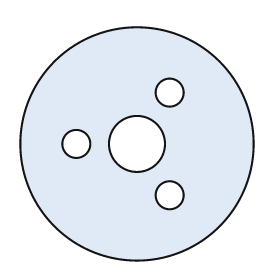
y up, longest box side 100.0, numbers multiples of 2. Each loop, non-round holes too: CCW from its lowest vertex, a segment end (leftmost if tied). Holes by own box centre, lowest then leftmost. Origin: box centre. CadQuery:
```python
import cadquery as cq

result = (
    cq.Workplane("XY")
    .moveTo(0.0, 0.0)
    .circle(50.0)
    .moveTo(14.0, -22.0)
    .circle(6.0)
    .moveTo(-26.0, 0.0)
    .circle(6.0)
    .moveTo(0.0, 0.0)
    .circle(12.0)
    .moveTo(14.0, 22.0)
    .circle(6.0)
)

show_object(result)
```